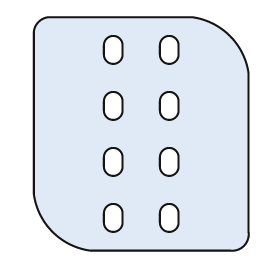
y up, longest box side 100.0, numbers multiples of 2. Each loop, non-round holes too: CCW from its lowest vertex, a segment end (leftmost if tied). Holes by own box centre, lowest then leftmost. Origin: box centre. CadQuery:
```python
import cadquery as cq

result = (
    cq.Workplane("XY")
    .moveTo(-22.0, -50.0)
    .lineTo(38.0, -50.0)
    .threePointArc((44.0, -48.0), (46.0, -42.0))
    .lineTo(46.0, 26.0)
    .threePointArc((38.0, 42.0), (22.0, 50.0))
    .lineTo(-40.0, 50.0)
    .threePointArc((-44.0, 48.0), (-46.0, 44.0))
    .lineTo(-46.0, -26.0)
    .threePointArc((-38.0, -42.0), (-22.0, -50.0))
    .close()
    .moveTo(-16.0, -38.0)
    .threePointArc((-12.0, -42.0), (-8.0, -38.0))
    .lineTo(-8.0, -34.0)
    .threePointArc((-12.0, -30.0), (-16.0, -34.0))
    .close()
    .moveTo(8.0, -38.0)
    .threePointArc((12.0, -42.0), (16.0, -38.0))
    .lineTo(16.0, -34.0)
    .threePointArc((12.0, -30.0), (8.0, -34.0))
    .close()
    .moveTo(-16.0, -14.0)
    .threePointArc((-12.0, -18.0), (-8.0, -14.0))
    .lineTo(-8.0, -10.0)
    .threePointArc((-12.0, -6.0), (-16.0, -10.0))
    .close()
    .moveTo(8.0, -14.0)
    .threePointArc((12.0, -18.0), (16.0, -14.0))
    .lineTo(16.0, -10.0)
    .threePointArc((12.0, -6.0), (8.0, -10.0))
    .close()
    .moveTo(-16.0, 10.0)
    .threePointArc((-12.0, 6.0), (-8.0, 10.0))
    .lineTo(-8.0, 14.0)
    .threePointArc((-12.0, 18.0), (-16.0, 14.0))
    .close()
    .moveTo(8.0, 10.0)
    .threePointArc((12.0, 6.0), (16.0, 10.0))
    .lineTo(16.0, 14.0)
    .threePointArc((12.0, 18.0), (8.0, 14.0))
    .close()
    .moveTo(-16.0, 34.0)
    .threePointArc((-12.0, 30.0), (-8.0, 34.0))
    .lineTo(-8.0, 38.0)
    .threePointArc((-12.0, 42.0), (-16.0, 38.0))
    .close()
    .moveTo(8.0, 34.0)
    .threePointArc((12.0, 30.0), (16.0, 34.0))
    .lineTo(16.0, 38.0)
    .threePointArc((12.0, 42.0), (8.0, 38.0))
    .close()
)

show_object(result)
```